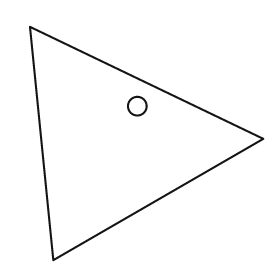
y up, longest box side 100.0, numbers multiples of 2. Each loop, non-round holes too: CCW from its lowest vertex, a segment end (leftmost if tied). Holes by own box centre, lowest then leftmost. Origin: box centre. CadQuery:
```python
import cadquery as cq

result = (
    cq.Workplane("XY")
    .moveTo(-40.0, -50.0)
    .lineTo(50.0, 2.0)
    .lineTo(-50.0, 50.0)
    .close()
    .moveTo(-4.0, 16.0)
    .circle(4.0)
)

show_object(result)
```